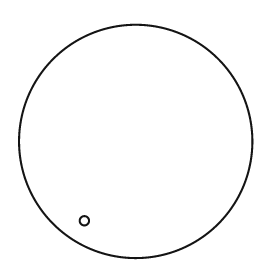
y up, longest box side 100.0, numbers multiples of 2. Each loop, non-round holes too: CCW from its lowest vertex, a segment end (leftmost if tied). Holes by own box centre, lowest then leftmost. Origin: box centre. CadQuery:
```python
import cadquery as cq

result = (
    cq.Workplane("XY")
    .moveTo(0.0, 0.0)
    .circle(50.0)
    .moveTo(-22.0, -34.0)
    .circle(2.0)
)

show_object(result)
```